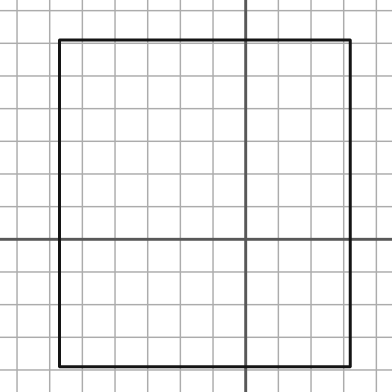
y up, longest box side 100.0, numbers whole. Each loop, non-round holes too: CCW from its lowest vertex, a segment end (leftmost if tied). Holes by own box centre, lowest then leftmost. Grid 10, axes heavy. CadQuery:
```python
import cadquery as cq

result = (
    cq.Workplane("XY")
    .moveTo(-57.0, -39.0)
    .lineTo(32.0, -39.0)
    .lineTo(32.0, 61.0)
    .lineTo(-57.0, 61.0)
    .close()
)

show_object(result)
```